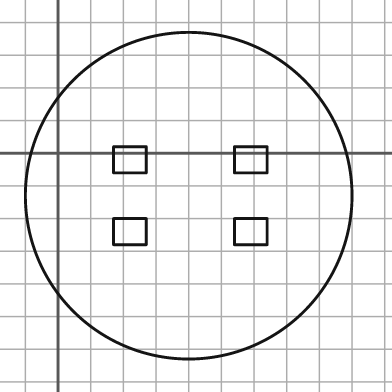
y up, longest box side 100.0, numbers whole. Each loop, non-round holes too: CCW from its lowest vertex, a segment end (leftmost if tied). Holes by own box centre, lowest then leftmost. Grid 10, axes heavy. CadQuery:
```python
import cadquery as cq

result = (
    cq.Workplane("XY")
    .moveTo(40.0, -13.0)
    .circle(50.0)
    .moveTo(17.0, -28.0)
    .lineTo(27.0, -28.0)
    .lineTo(27.0, -20.0)
    .lineTo(17.0, -20.0)
    .close()
    .moveTo(54.0, -28.0)
    .lineTo(64.0, -28.0)
    .lineTo(64.0, -20.0)
    .lineTo(54.0, -20.0)
    .close()
    .moveTo(17.0, -6.0)
    .lineTo(27.0, -6.0)
    .lineTo(27.0, 2.0)
    .lineTo(17.0, 2.0)
    .close()
    .moveTo(54.0, -6.0)
    .lineTo(64.0, -6.0)
    .lineTo(64.0, 2.0)
    .lineTo(54.0, 2.0)
    .close()
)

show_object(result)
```